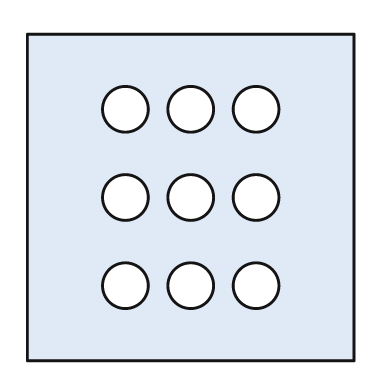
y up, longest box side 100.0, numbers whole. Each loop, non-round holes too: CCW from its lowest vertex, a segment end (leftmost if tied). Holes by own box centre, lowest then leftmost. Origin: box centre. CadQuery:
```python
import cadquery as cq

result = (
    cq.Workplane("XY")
    .moveTo(-50.0, -50.0)
    .lineTo(50.0, -50.0)
    .lineTo(50.0, 50.0)
    .lineTo(-50.0, 50.0)
    .close()
    .moveTo(-20.0, -27.0)
    .circle(7.0)
    .moveTo(0.0, -27.0)
    .circle(7.0)
    .moveTo(20.0, -27.0)
    .circle(7.0)
    .moveTo(-20.0, 0.0)
    .circle(7.0)
    .moveTo(0.0, 0.0)
    .circle(7.0)
    .moveTo(20.0, 0.0)
    .circle(7.0)
    .moveTo(-20.0, 27.0)
    .circle(7.0)
    .moveTo(0.0, 27.0)
    .circle(7.0)
    .moveTo(20.0, 27.0)
    .circle(7.0)
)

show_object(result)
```